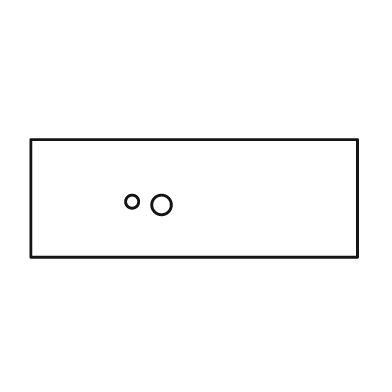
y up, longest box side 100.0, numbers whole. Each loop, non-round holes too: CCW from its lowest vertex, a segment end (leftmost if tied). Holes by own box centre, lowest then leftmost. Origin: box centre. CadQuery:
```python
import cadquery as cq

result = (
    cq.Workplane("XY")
    .moveTo(-50.0, -18.0)
    .lineTo(50.0, -18.0)
    .lineTo(50.0, 18.0)
    .lineTo(-50.0, 18.0)
    .close()
    .moveTo(-10.0, -2.0)
    .circle(3.0)
    .moveTo(-19.0, -1.0)
    .circle(2.0)
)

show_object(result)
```